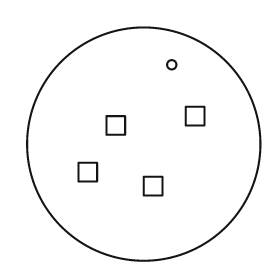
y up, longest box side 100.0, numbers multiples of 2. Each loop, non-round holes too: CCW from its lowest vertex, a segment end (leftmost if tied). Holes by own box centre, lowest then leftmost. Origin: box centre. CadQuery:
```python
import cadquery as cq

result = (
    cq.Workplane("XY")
    .moveTo(0.0, 0.0)
    .circle(50.0)
    .moveTo(0.0, -22.0)
    .lineTo(8.0, -22.0)
    .lineTo(8.0, -14.0)
    .lineTo(0.0, -14.0)
    .close()
    .moveTo(-28.0, -16.0)
    .lineTo(-20.0, -16.0)
    .lineTo(-20.0, -8.0)
    .lineTo(-28.0, -8.0)
    .close()
    .moveTo(-16.0, 4.0)
    .lineTo(-8.0, 4.0)
    .lineTo(-8.0, 12.0)
    .lineTo(-16.0, 12.0)
    .close()
    .moveTo(18.0, 8.0)
    .lineTo(26.0, 8.0)
    .lineTo(26.0, 16.0)
    .lineTo(18.0, 16.0)
    .close()
    .moveTo(12.0, 34.0)
    .circle(2.0)
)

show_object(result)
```